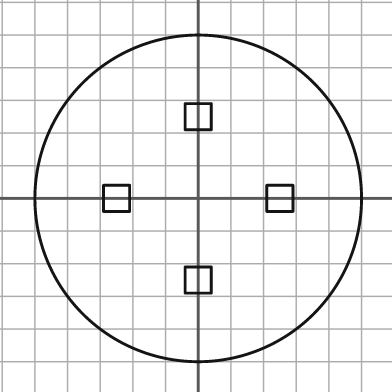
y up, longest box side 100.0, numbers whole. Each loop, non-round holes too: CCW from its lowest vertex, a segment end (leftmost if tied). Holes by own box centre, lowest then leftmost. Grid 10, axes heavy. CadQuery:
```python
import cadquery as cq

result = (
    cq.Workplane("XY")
    .moveTo(0.0, 0.0)
    .circle(50.0)
    .moveTo(-4.0, -29.0)
    .lineTo(4.0, -29.0)
    .lineTo(4.0, -21.0)
    .lineTo(-4.0, -21.0)
    .close()
    .moveTo(-29.0, -4.0)
    .lineTo(-21.0, -4.0)
    .lineTo(-21.0, 4.0)
    .lineTo(-29.0, 4.0)
    .close()
    .moveTo(21.0, -4.0)
    .lineTo(29.0, -4.0)
    .lineTo(29.0, 4.0)
    .lineTo(21.0, 4.0)
    .close()
    .moveTo(-4.0, 21.0)
    .lineTo(4.0, 21.0)
    .lineTo(4.0, 29.0)
    .lineTo(-4.0, 29.0)
    .close()
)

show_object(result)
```